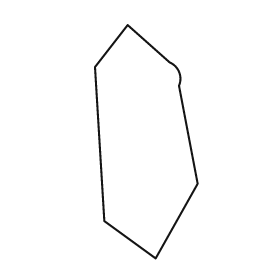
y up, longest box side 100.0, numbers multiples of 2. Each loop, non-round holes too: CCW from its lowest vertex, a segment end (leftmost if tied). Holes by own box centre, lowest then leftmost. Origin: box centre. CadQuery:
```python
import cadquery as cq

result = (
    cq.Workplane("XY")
    .moveTo(4.0, -50.0)
    .lineTo(22.0, -18.0)
    .lineTo(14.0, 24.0)
    .threePointArc((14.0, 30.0), (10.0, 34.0))
    .lineTo(-8.0, 50.0)
    .lineTo(-22.0, 32.0)
    .lineTo(-18.0, -34.0)
    .close()
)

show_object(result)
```